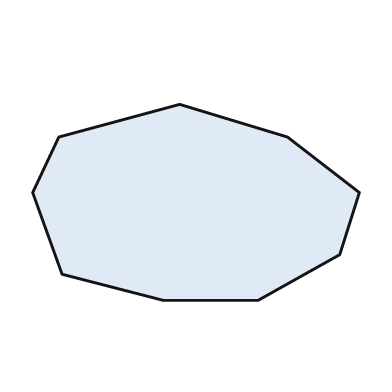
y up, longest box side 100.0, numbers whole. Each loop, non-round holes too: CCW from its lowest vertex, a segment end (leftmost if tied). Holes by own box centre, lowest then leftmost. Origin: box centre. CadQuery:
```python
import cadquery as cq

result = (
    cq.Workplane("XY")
    .moveTo(-10.0, -30.0)
    .lineTo(19.0, -30.0)
    .lineTo(44.0, -16.0)
    .lineTo(50.0, 3.0)
    .lineTo(28.0, 20.0)
    .lineTo(-5.0, 30.0)
    .lineTo(-42.0, 20.0)
    .lineTo(-50.0, 3.0)
    .lineTo(-41.0, -22.0)
    .close()
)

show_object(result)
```